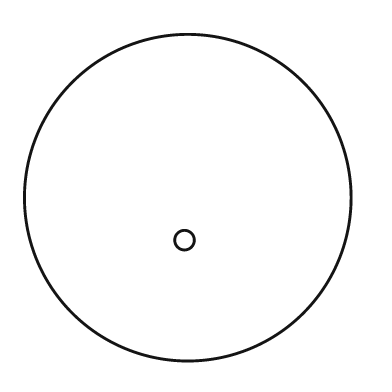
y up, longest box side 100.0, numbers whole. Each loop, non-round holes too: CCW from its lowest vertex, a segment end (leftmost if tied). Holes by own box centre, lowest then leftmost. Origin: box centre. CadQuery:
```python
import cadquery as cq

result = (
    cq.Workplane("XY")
    .moveTo(0.0, 0.0)
    .circle(50.0)
    .moveTo(-1.0, -13.0)
    .circle(3.0)
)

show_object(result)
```